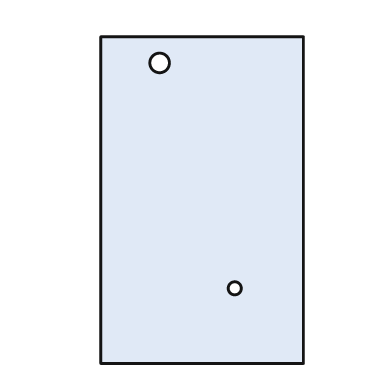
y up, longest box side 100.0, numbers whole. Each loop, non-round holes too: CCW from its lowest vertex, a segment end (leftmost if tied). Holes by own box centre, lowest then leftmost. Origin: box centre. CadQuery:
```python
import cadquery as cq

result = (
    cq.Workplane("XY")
    .moveTo(-31.0, -50.0)
    .lineTo(31.0, -50.0)
    .lineTo(31.0, 50.0)
    .lineTo(-31.0, 50.0)
    .close()
    .moveTo(10.0, -27.0)
    .circle(2.0)
    .moveTo(-13.0, 42.0)
    .circle(3.0)
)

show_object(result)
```